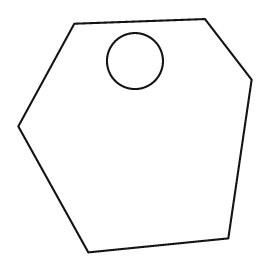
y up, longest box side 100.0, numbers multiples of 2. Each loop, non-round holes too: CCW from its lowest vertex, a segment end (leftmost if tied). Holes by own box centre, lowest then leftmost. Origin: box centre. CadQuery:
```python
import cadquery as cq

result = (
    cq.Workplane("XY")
    .moveTo(-20.0, -50.0)
    .lineTo(40.0, -44.0)
    .lineTo(50.0, 24.0)
    .lineTo(30.0, 50.0)
    .lineTo(-26.0, 48.0)
    .lineTo(-50.0, 4.0)
    .close()
    .moveTo(0.0, 32.0)
    .circle(12.0)
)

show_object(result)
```